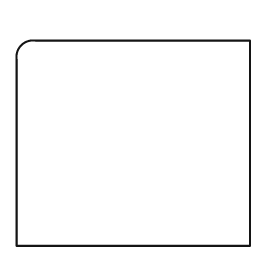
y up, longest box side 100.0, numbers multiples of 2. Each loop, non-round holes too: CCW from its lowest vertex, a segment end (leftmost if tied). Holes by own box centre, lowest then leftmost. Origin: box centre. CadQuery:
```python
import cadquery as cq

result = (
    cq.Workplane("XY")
    .moveTo(-50.0, -44.0)
    .lineTo(50.0, -44.0)
    .lineTo(50.0, 44.0)
    .lineTo(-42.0, 44.0)
    .threePointArc((-48.0, 42.0), (-50.0, 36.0))
    .close()
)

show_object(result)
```